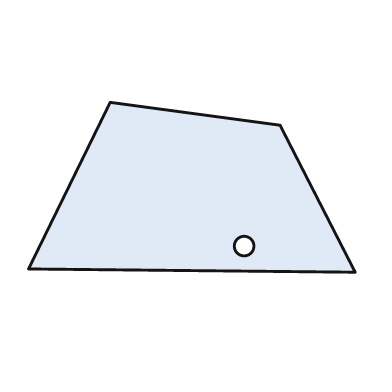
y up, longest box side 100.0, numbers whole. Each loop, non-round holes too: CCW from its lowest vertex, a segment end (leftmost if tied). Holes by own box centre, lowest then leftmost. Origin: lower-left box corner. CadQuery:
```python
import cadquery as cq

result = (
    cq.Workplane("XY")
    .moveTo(100.0, 0.0)
    .lineTo(77.0, 45.0)
    .lineTo(25.0, 52.0)
    .lineTo(0.0, 1.0)
    .close()
    .moveTo(66.0, 8.0)
    .circle(3.0)
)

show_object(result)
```